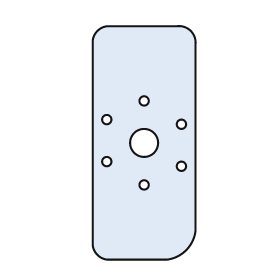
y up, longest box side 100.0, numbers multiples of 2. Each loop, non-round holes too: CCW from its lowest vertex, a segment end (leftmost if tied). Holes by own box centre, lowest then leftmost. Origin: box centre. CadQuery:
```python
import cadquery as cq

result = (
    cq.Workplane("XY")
    .moveTo(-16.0, -50.0)
    .lineTo(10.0, -50.0)
    .threePointArc((18.0, -46.0), (22.0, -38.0))
    .lineTo(22.0, 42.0)
    .threePointArc((20.0, 48.0), (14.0, 50.0))
    .lineTo(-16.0, 50.0)
    .threePointArc((-20.0, 48.0), (-22.0, 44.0))
    .lineTo(-22.0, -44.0)
    .threePointArc((-20.0, -48.0), (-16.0, -50.0))
    .close()
    .moveTo(0.0, -18.0)
    .circle(2.0)
    .moveTo(16.0, -10.0)
    .circle(2.0)
    .moveTo(-16.0, -8.0)
    .circle(2.0)
    .moveTo(0.0, 0.0)
    .circle(6.0)
    .moveTo(16.0, 8.0)
    .circle(2.0)
    .moveTo(-16.0, 10.0)
    .circle(2.0)
    .moveTo(0.0, 18.0)
    .circle(2.0)
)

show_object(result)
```